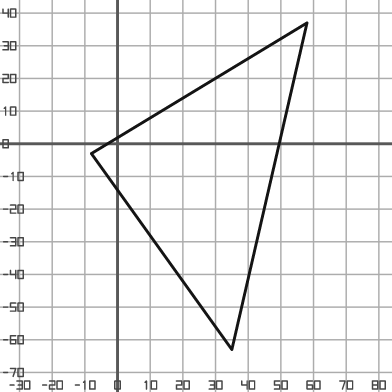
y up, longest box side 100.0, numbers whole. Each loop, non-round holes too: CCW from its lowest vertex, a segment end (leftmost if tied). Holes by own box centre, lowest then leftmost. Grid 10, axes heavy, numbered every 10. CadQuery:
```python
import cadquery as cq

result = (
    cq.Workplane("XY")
    .moveTo(35.0, -63.0)
    .lineTo(58.0, 37.0)
    .lineTo(-8.0, -3.0)
    .close()
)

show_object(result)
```